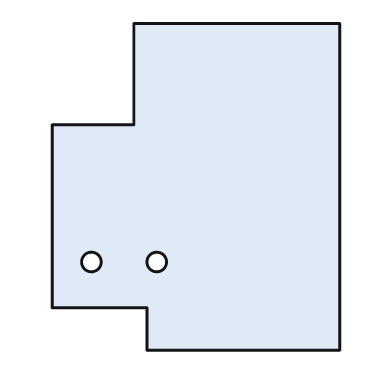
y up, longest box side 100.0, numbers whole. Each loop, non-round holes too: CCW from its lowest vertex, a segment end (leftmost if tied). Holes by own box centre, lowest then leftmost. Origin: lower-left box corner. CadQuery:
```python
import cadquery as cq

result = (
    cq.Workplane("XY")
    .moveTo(29.0, 0.0)
    .lineTo(88.0, 0.0)
    .lineTo(88.0, 100.0)
    .lineTo(25.0, 100.0)
    .lineTo(25.0, 69.0)
    .lineTo(0.0, 69.0)
    .lineTo(0.0, 13.0)
    .lineTo(29.0, 13.0)
    .close()
    .moveTo(12.0, 27.0)
    .circle(3.0)
    .moveTo(32.0, 27.0)
    .circle(3.0)
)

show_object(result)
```